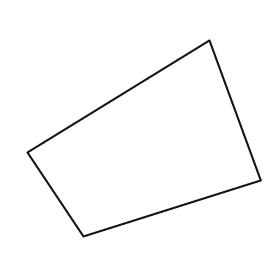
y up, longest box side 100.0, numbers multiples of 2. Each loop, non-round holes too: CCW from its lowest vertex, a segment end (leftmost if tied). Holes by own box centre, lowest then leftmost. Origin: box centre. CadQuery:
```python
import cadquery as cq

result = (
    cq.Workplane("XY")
    .moveTo(-26.0, -42.0)
    .lineTo(50.0, -18.0)
    .lineTo(28.0, 42.0)
    .lineTo(-50.0, -6.0)
    .close()
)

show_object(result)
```